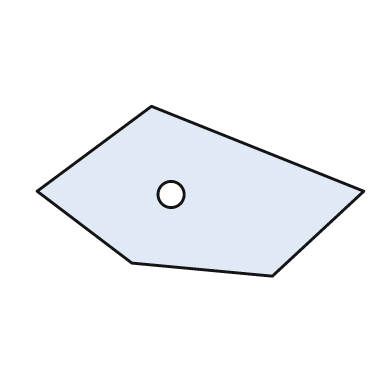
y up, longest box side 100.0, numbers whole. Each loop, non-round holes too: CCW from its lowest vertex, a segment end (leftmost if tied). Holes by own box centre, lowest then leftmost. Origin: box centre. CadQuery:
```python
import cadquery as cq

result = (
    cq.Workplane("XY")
    .moveTo(22.0, -26.0)
    .lineTo(50.0, 0.0)
    .lineTo(-15.0, 26.0)
    .lineTo(-50.0, 0.0)
    .lineTo(-21.0, -22.0)
    .close()
    .moveTo(-9.0, -1.0)
    .circle(4.0)
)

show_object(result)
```